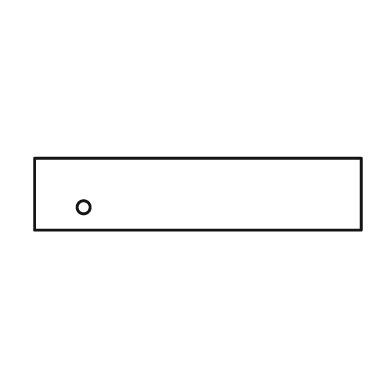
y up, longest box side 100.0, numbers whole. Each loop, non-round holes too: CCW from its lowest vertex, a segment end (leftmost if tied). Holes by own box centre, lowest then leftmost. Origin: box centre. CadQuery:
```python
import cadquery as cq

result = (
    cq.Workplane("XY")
    .moveTo(-50.0, -11.0)
    .lineTo(50.0, -11.0)
    .lineTo(50.0, 11.0)
    .lineTo(-50.0, 11.0)
    .close()
    .moveTo(-35.0, -4.0)
    .circle(2.0)
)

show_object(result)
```